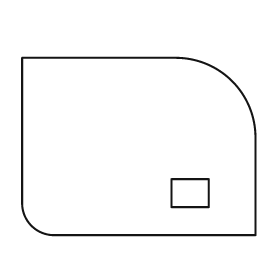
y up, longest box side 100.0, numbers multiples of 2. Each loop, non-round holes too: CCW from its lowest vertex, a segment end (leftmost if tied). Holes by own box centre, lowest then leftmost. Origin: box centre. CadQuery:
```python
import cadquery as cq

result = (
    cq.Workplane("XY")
    .moveTo(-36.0, -38.0)
    .lineTo(50.0, -38.0)
    .lineTo(50.0, 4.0)
    .threePointArc((40.0, 28.0), (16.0, 38.0))
    .lineTo(-50.0, 38.0)
    .lineTo(-50.0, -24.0)
    .threePointArc((-46.0, -34.0), (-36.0, -38.0))
    .close()
    .moveTo(14.0, -26.0)
    .lineTo(30.0, -26.0)
    .lineTo(30.0, -14.0)
    .lineTo(14.0, -14.0)
    .close()
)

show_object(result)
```